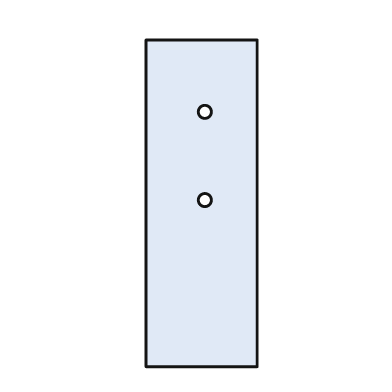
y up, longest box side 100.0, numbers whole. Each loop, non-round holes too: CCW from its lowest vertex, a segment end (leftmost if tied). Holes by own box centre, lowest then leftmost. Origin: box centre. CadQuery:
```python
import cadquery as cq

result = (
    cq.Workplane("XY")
    .moveTo(-17.0, -50.0)
    .lineTo(17.0, -50.0)
    .lineTo(17.0, 50.0)
    .lineTo(-17.0, 50.0)
    .close()
    .moveTo(1.0, 1.0)
    .circle(2.0)
    .moveTo(1.0, 28.0)
    .circle(2.0)
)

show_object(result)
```